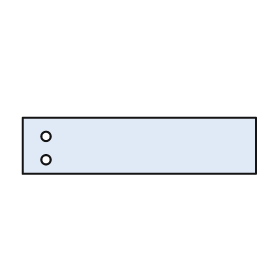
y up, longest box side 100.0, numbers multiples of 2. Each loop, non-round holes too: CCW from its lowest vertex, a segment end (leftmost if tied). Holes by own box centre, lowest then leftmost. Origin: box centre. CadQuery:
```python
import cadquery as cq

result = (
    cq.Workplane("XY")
    .moveTo(-50.0, -12.0)
    .lineTo(50.0, -12.0)
    .lineTo(50.0, 12.0)
    .lineTo(-50.0, 12.0)
    .close()
    .moveTo(-40.0, -6.0)
    .circle(2.0)
    .moveTo(-40.0, 4.0)
    .circle(2.0)
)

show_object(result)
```